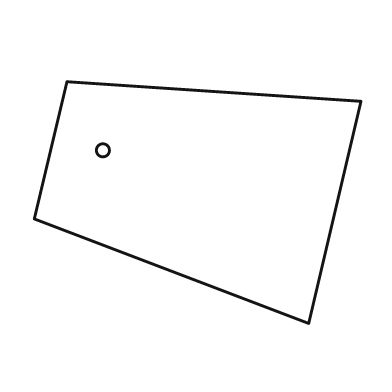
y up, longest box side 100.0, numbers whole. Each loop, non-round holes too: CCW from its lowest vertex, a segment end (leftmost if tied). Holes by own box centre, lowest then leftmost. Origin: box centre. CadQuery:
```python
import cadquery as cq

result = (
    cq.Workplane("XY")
    .moveTo(34.0, -37.0)
    .lineTo(50.0, 31.0)
    .lineTo(-40.0, 37.0)
    .lineTo(-50.0, -5.0)
    .close()
    .moveTo(-29.0, 16.0)
    .circle(2.0)
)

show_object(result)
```